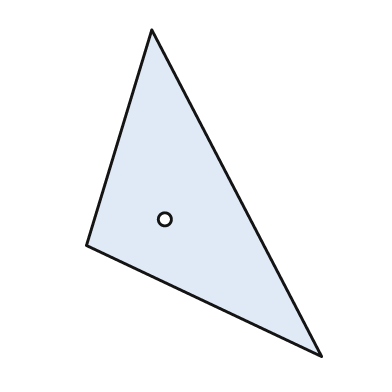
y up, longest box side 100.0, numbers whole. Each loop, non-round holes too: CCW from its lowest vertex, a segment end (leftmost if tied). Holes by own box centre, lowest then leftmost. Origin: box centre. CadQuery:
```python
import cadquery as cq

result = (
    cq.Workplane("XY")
    .moveTo(36.0, -50.0)
    .lineTo(-16.0, 50.0)
    .lineTo(-36.0, -16.0)
    .close()
    .moveTo(-12.0, -8.0)
    .circle(2.0)
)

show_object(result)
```